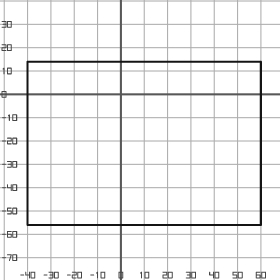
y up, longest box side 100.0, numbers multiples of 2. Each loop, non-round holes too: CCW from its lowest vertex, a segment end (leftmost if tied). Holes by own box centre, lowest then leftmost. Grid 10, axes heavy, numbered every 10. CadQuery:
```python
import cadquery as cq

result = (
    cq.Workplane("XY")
    .moveTo(-40.0, -56.0)
    .lineTo(60.0, -56.0)
    .lineTo(60.0, 14.0)
    .lineTo(-40.0, 14.0)
    .close()
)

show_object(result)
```